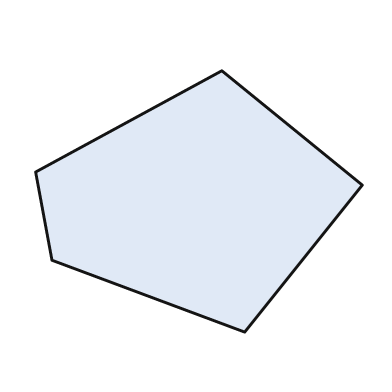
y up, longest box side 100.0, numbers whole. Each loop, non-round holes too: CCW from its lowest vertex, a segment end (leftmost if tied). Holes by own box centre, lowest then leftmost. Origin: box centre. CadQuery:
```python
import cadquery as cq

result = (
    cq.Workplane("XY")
    .moveTo(14.0, -40.0)
    .lineTo(50.0, 5.0)
    .lineTo(7.0, 40.0)
    .lineTo(-50.0, 9.0)
    .lineTo(-45.0, -18.0)
    .close()
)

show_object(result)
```